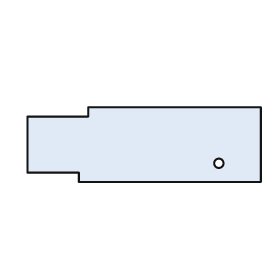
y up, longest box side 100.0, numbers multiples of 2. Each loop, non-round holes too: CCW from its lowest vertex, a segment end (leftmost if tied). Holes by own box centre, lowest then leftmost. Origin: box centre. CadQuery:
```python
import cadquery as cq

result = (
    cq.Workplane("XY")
    .moveTo(-28.0, -16.0)
    .lineTo(50.0, -16.0)
    .lineTo(50.0, 16.0)
    .lineTo(-24.0, 16.0)
    .lineTo(-24.0, 12.0)
    .lineTo(-50.0, 12.0)
    .lineTo(-50.0, -12.0)
    .lineTo(-28.0, -12.0)
    .close()
    .moveTo(32.0, -8.0)
    .circle(2.0)
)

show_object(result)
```